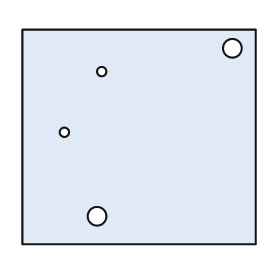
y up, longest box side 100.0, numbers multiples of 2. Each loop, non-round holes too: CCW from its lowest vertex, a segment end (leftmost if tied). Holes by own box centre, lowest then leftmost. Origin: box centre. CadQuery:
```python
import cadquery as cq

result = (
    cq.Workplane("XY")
    .moveTo(-50.0, -46.0)
    .lineTo(50.0, -46.0)
    .lineTo(50.0, 46.0)
    .lineTo(-50.0, 46.0)
    .close()
    .moveTo(-18.0, -34.0)
    .circle(4.0)
    .moveTo(-32.0, 2.0)
    .circle(2.0)
    .moveTo(-16.0, 28.0)
    .circle(2.0)
    .moveTo(40.0, 38.0)
    .circle(4.0)
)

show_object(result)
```